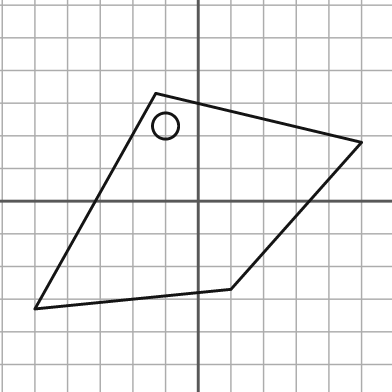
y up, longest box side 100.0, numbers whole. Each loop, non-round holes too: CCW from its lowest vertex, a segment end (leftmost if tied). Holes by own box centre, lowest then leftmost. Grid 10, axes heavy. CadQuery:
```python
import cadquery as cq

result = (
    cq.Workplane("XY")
    .moveTo(-50.0, -33.0)
    .lineTo(10.0, -27.0)
    .lineTo(50.0, 18.0)
    .lineTo(-13.0, 33.0)
    .close()
    .moveTo(-10.0, 23.0)
    .circle(4.0)
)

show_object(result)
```